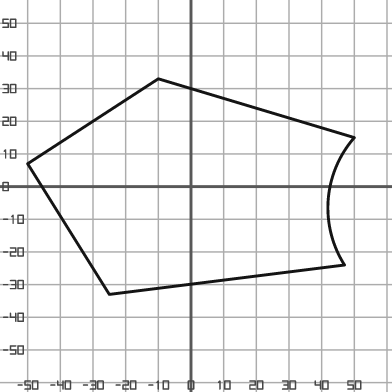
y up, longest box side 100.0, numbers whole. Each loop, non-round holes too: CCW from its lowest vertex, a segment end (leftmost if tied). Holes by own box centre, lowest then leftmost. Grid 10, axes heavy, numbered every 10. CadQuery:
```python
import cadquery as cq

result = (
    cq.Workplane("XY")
    .moveTo(-25.0, -33.0)
    .lineTo(47.0, -24.0)
    .threePointArc((42.0, -4.0), (50.0, 15.0))
    .lineTo(-10.0, 33.0)
    .lineTo(-50.0, 7.0)
    .close()
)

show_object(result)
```